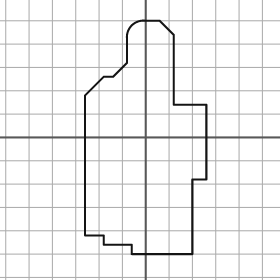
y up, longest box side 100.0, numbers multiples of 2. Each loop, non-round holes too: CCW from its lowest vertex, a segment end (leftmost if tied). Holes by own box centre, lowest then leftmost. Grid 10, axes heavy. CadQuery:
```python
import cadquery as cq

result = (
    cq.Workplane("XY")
    .moveTo(-6.0, -50.0)
    .lineTo(20.0, -50.0)
    .lineTo(20.0, -18.0)
    .lineTo(26.0, -18.0)
    .lineTo(26.0, 14.0)
    .lineTo(12.0, 14.0)
    .lineTo(12.0, 44.0)
    .lineTo(6.0, 50.0)
    .lineTo(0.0, 50.0)
    .threePointArc((-6.0, 48.0), (-8.0, 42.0))
    .lineTo(-8.0, 32.0)
    .lineTo(-14.0, 26.0)
    .lineTo(-18.0, 26.0)
    .lineTo(-26.0, 18.0)
    .lineTo(-26.0, -42.0)
    .lineTo(-18.0, -42.0)
    .lineTo(-18.0, -46.0)
    .lineTo(-6.0, -46.0)
    .close()
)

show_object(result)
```